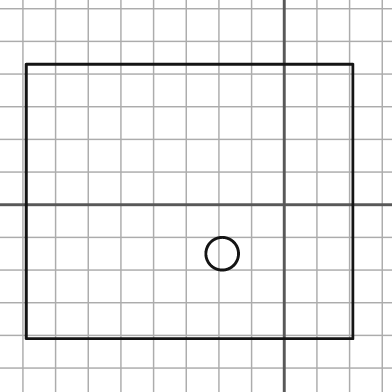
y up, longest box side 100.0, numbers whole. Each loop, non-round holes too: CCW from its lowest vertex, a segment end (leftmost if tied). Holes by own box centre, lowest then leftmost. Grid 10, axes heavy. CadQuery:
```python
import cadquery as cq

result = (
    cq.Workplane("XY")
    .moveTo(-79.0, -41.0)
    .lineTo(21.0, -41.0)
    .lineTo(21.0, 43.0)
    .lineTo(-79.0, 43.0)
    .close()
    .moveTo(-19.0, -15.0)
    .circle(5.0)
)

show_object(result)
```